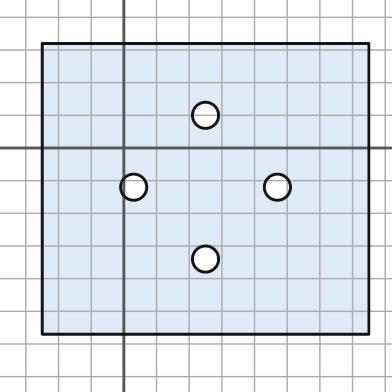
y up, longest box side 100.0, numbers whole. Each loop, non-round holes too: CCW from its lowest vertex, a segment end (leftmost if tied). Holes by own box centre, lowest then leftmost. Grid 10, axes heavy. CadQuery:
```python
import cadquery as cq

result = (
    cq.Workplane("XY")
    .moveTo(-25.0, -57.0)
    .lineTo(75.0, -57.0)
    .lineTo(75.0, 32.0)
    .lineTo(-25.0, 32.0)
    .close()
    .moveTo(25.0, -34.0)
    .circle(4.0)
    .moveTo(3.0, -12.0)
    .circle(4.0)
    .moveTo(47.0, -12.0)
    .circle(4.0)
    .moveTo(25.0, 10.0)
    .circle(4.0)
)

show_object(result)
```